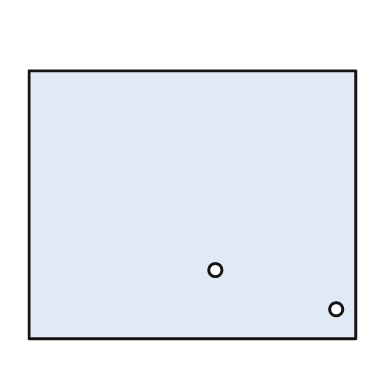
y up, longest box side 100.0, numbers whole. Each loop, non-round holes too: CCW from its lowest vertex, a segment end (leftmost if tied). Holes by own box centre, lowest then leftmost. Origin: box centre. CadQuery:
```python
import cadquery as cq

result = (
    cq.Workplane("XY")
    .moveTo(-50.0, -41.0)
    .lineTo(50.0, -41.0)
    .lineTo(50.0, 41.0)
    .lineTo(-50.0, 41.0)
    .close()
    .moveTo(44.0, -32.0)
    .circle(2.0)
    .moveTo(7.0, -20.0)
    .circle(2.0)
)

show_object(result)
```